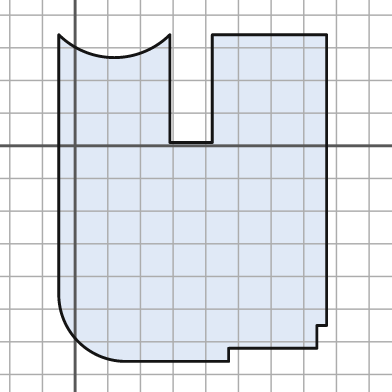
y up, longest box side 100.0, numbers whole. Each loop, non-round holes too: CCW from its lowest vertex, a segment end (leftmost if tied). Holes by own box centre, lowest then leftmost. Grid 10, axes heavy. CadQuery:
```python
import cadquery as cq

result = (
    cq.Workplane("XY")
    .moveTo(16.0, -66.0)
    .lineTo(47.0, -66.0)
    .lineTo(47.0, -62.0)
    .lineTo(74.0, -62.0)
    .lineTo(74.0, -55.0)
    .lineTo(77.0, -55.0)
    .lineTo(77.0, 34.0)
    .lineTo(42.0, 34.0)
    .lineTo(42.0, 1.0)
    .lineTo(29.0, 1.0)
    .lineTo(29.0, 34.0)
    .threePointArc((12.0, 27.0), (-5.0, 34.0))
    .lineTo(-5.0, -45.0)
    .threePointArc((1.0, -60.0), (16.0, -66.0))
    .close()
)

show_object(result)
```